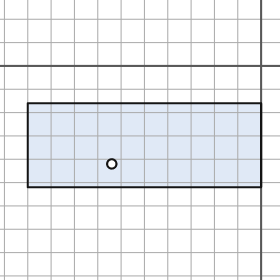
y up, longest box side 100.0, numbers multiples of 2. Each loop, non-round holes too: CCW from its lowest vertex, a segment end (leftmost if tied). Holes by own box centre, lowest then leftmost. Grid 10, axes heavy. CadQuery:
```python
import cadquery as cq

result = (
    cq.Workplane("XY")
    .moveTo(-100.0, -52.0)
    .lineTo(0.0, -52.0)
    .lineTo(0.0, -16.0)
    .lineTo(-100.0, -16.0)
    .close()
    .moveTo(-64.0, -42.0)
    .circle(2.0)
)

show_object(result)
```